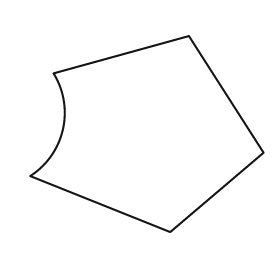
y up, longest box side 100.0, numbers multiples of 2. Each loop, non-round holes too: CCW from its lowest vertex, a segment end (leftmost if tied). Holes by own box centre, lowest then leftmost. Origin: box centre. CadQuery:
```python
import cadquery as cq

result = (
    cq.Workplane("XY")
    .moveTo(10.0, -42.0)
    .lineTo(50.0, -8.0)
    .lineTo(18.0, 42.0)
    .lineTo(-40.0, 26.0)
    .threePointArc((-36.0, 2.0), (-50.0, -18.0))
    .close()
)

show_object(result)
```